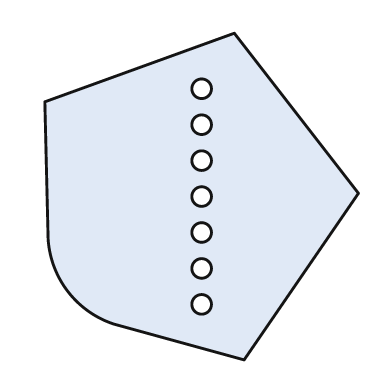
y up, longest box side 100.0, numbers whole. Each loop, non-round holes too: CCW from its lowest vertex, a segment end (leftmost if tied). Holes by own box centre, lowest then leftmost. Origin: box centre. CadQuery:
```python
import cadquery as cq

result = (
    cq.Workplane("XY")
    .moveTo(13.0, -50.0)
    .lineTo(48.0, 1.0)
    .lineTo(10.0, 50.0)
    .lineTo(-48.0, 29.0)
    .lineTo(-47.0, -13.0)
    .threePointArc((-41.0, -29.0), (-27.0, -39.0))
    .close()
    .moveTo(0.0, -33.0)
    .circle(3.0)
    .moveTo(0.0, -22.0)
    .circle(3.0)
    .moveTo(0.0, -11.0)
    .circle(3.0)
    .moveTo(0.0, 0.0)
    .circle(3.0)
    .moveTo(0.0, 11.0)
    .circle(3.0)
    .moveTo(0.0, 22.0)
    .circle(3.0)
    .moveTo(0.0, 33.0)
    .circle(3.0)
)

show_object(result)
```